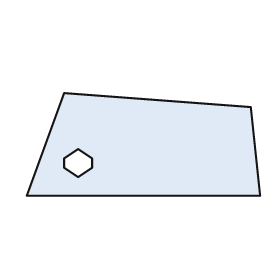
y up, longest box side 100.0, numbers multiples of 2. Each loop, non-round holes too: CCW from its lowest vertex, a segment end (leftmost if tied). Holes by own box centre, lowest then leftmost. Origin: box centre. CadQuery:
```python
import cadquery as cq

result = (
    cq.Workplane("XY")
    .moveTo(-50.0, -22.0)
    .lineTo(50.0, -22.0)
    .lineTo(46.0, 16.0)
    .lineTo(-34.0, 22.0)
    .close()
    .moveTo(-28.0, -14.0)
    .lineTo(-22.0, -10.0)
    .lineTo(-22.0, -6.0)
    .lineTo(-28.0, -2.0)
    .lineTo(-34.0, -6.0)
    .lineTo(-34.0, -10.0)
    .close()
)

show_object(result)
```